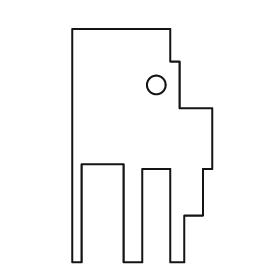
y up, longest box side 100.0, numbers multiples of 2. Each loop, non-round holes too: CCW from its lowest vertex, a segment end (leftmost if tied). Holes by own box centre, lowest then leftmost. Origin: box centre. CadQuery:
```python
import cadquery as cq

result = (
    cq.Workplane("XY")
    .moveTo(-30.0, -50.0)
    .lineTo(-26.0, -50.0)
    .lineTo(-26.0, -8.0)
    .lineTo(-8.0, -8.0)
    .lineTo(-8.0, -50.0)
    .lineTo(0.0, -50.0)
    .lineTo(0.0, -10.0)
    .lineTo(12.0, -10.0)
    .lineTo(12.0, -50.0)
    .lineTo(18.0, -50.0)
    .lineTo(18.0, -30.0)
    .lineTo(26.0, -30.0)
    .lineTo(26.0, -10.0)
    .lineTo(30.0, -10.0)
    .lineTo(30.0, 16.0)
    .lineTo(16.0, 16.0)
    .lineTo(16.0, 36.0)
    .lineTo(12.0, 36.0)
    .lineTo(12.0, 50.0)
    .lineTo(-30.0, 50.0)
    .close()
    .moveTo(6.0, 26.0)
    .circle(4.0)
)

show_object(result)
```